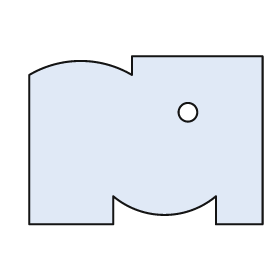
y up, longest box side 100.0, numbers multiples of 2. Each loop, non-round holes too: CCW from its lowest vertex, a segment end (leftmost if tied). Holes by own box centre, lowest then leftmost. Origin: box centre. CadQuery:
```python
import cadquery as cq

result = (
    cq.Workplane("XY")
    .moveTo(-50.0, -36.0)
    .lineTo(-14.0, -36.0)
    .lineTo(-14.0, -24.0)
    .threePointArc((8.0, -32.0), (30.0, -24.0))
    .lineTo(30.0, -36.0)
    .lineTo(50.0, -36.0)
    .lineTo(50.0, 36.0)
    .lineTo(-6.0, 36.0)
    .lineTo(-6.0, 28.0)
    .threePointArc((-28.0, 34.0), (-50.0, 28.0))
    .close()
    .moveTo(18.0, 12.0)
    .circle(4.0)
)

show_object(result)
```